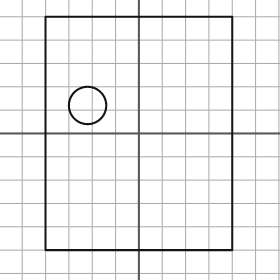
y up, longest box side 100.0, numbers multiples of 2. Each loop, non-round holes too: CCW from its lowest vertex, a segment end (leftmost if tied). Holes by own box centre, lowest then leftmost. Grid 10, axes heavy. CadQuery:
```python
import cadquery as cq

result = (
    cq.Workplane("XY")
    .moveTo(-40.0, -50.0)
    .lineTo(40.0, -50.0)
    .lineTo(40.0, 50.0)
    .lineTo(-40.0, 50.0)
    .close()
    .moveTo(-22.0, 12.0)
    .circle(8.0)
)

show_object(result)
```